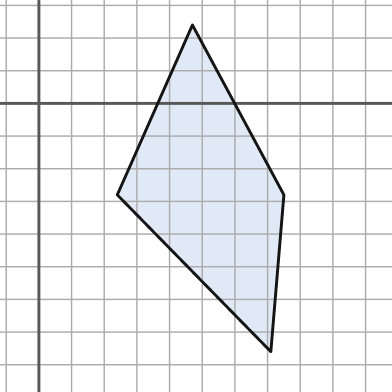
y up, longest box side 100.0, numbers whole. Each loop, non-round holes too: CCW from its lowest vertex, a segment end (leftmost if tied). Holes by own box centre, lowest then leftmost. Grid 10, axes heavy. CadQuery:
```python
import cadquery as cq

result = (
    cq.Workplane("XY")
    .moveTo(71.0, -76.0)
    .lineTo(75.0, -28.0)
    .lineTo(47.0, 24.0)
    .lineTo(24.0, -28.0)
    .close()
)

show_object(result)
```